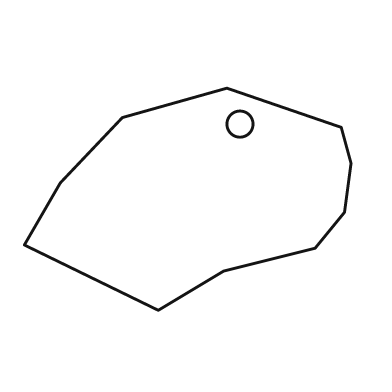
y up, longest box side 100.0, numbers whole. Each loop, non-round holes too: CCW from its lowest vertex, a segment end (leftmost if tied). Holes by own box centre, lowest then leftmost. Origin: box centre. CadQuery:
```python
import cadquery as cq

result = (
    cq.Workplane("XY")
    .moveTo(-9.0, -34.0)
    .lineTo(11.0, -22.0)
    .lineTo(39.0, -15.0)
    .lineTo(48.0, -4.0)
    .lineTo(50.0, 11.0)
    .lineTo(47.0, 22.0)
    .lineTo(12.0, 34.0)
    .lineTo(-20.0, 25.0)
    .lineTo(-39.0, 5.0)
    .lineTo(-50.0, -14.0)
    .close()
    .moveTo(16.0, 23.0)
    .circle(4.0)
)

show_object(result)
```